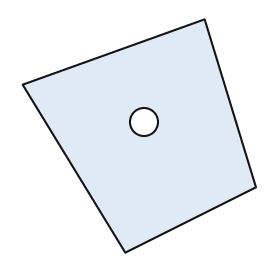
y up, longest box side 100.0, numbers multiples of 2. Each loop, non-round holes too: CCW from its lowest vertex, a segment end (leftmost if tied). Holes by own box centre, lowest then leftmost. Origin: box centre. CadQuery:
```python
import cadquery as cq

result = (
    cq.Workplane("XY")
    .moveTo(-6.0, -50.0)
    .lineTo(50.0, -22.0)
    .lineTo(28.0, 50.0)
    .lineTo(-50.0, 22.0)
    .close()
    .moveTo(2.0, 6.0)
    .circle(6.0)
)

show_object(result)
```